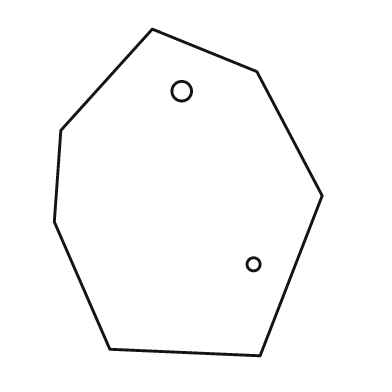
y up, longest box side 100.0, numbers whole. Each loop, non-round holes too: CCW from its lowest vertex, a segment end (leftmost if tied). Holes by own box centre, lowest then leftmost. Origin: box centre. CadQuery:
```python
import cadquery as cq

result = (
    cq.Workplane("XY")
    .moveTo(22.0, -50.0)
    .lineTo(41.0, -1.0)
    .lineTo(21.0, 37.0)
    .lineTo(-11.0, 50.0)
    .lineTo(-39.0, 19.0)
    .lineTo(-41.0, -9.0)
    .lineTo(-24.0, -48.0)
    .close()
    .moveTo(20.0, -22.0)
    .circle(2.0)
    .moveTo(-2.0, 31.0)
    .circle(3.0)
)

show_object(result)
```